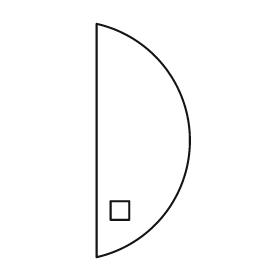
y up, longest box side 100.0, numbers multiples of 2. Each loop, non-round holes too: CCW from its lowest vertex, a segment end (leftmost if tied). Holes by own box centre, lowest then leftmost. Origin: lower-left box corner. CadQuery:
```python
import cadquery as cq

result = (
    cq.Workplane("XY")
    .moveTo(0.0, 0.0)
    .threePointArc((40.0, 50.0), (0.0, 100.0))
    .close()
    .moveTo(6.0, 16.0)
    .lineTo(14.0, 16.0)
    .lineTo(14.0, 24.0)
    .lineTo(6.0, 24.0)
    .close()
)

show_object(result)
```